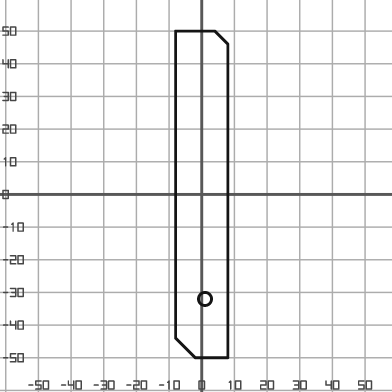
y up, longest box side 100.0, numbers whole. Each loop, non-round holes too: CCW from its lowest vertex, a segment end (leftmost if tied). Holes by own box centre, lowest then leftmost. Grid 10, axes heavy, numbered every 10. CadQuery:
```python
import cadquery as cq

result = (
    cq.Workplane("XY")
    .moveTo(-2.0, -50.0)
    .lineTo(8.0, -50.0)
    .lineTo(8.0, 46.0)
    .lineTo(4.0, 50.0)
    .lineTo(-8.0, 50.0)
    .lineTo(-8.0, -44.0)
    .close()
    .moveTo(1.0, -32.0)
    .circle(2.0)
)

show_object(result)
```